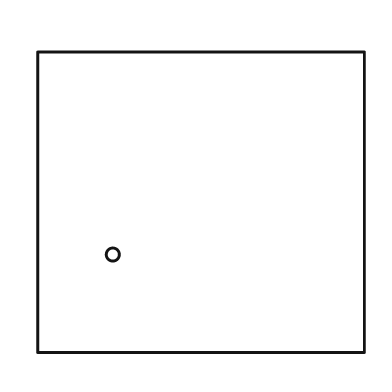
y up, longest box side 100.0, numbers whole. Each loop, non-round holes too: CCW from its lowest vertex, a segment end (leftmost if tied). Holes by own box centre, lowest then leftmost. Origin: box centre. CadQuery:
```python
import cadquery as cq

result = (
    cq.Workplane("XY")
    .moveTo(-50.0, -46.0)
    .lineTo(50.0, -46.0)
    .lineTo(50.0, 46.0)
    .lineTo(-50.0, 46.0)
    .close()
    .moveTo(-27.0, -16.0)
    .circle(2.0)
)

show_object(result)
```